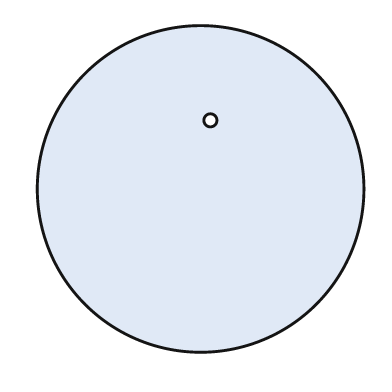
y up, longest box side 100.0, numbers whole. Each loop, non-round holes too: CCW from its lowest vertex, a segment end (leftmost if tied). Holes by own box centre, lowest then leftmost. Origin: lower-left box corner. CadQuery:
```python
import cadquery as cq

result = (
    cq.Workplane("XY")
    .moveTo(50.0, 50.0)
    .circle(50.0)
    .moveTo(53.0, 71.0)
    .circle(2.0)
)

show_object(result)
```